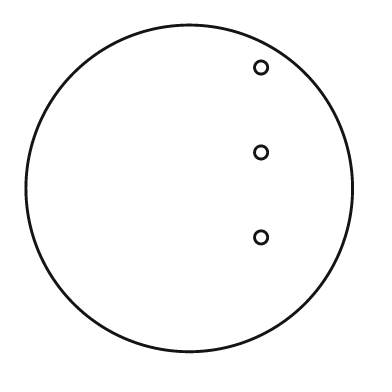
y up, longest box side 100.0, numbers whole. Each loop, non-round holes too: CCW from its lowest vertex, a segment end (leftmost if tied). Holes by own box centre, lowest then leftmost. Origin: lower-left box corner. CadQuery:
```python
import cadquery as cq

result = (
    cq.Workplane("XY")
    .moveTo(50.0, 50.0)
    .circle(50.0)
    .moveTo(72.0, 35.0)
    .circle(2.0)
    .moveTo(72.0, 61.0)
    .circle(2.0)
    .moveTo(72.0, 87.0)
    .circle(2.0)
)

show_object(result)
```